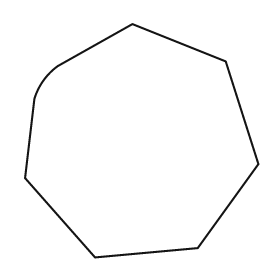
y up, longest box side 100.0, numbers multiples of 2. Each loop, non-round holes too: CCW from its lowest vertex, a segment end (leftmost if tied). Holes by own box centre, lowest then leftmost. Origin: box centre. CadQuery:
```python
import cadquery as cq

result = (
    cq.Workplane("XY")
    .moveTo(-20.0, -50.0)
    .lineTo(24.0, -46.0)
    .lineTo(50.0, -10.0)
    .lineTo(36.0, 34.0)
    .lineTo(-4.0, 50.0)
    .lineTo(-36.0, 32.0)
    .threePointArc((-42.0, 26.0), (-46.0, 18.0))
    .lineTo(-50.0, -16.0)
    .close()
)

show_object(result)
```